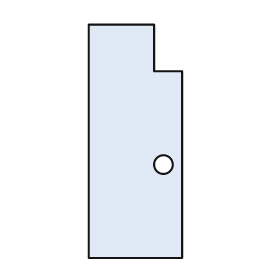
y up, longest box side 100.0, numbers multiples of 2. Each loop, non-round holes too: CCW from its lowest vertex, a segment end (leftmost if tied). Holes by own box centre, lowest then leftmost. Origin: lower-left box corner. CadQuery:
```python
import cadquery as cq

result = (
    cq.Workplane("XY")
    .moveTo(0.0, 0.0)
    .lineTo(40.0, 0.0)
    .lineTo(40.0, 80.0)
    .lineTo(28.0, 80.0)
    .lineTo(28.0, 100.0)
    .lineTo(0.0, 100.0)
    .close()
    .moveTo(32.0, 40.0)
    .circle(4.0)
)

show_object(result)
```